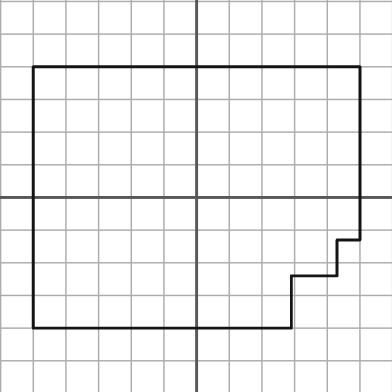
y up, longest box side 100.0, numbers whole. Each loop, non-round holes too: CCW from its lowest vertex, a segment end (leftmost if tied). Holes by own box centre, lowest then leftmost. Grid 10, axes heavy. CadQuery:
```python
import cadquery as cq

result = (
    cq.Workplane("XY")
    .moveTo(-50.0, -40.0)
    .lineTo(29.0, -40.0)
    .lineTo(29.0, -24.0)
    .lineTo(43.0, -24.0)
    .lineTo(43.0, -13.0)
    .lineTo(50.0, -13.0)
    .lineTo(50.0, 40.0)
    .lineTo(-50.0, 40.0)
    .close()
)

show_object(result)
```